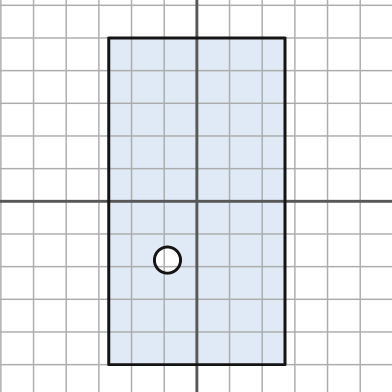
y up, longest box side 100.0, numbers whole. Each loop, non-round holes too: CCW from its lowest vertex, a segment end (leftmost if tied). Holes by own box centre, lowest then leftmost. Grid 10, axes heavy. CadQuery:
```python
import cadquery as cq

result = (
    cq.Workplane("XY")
    .moveTo(-27.0, -50.0)
    .lineTo(27.0, -50.0)
    .lineTo(27.0, 50.0)
    .lineTo(-27.0, 50.0)
    .close()
    .moveTo(-9.0, -18.0)
    .circle(4.0)
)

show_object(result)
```